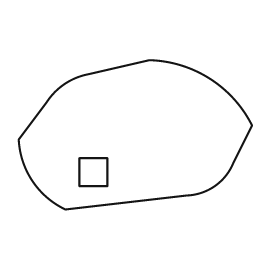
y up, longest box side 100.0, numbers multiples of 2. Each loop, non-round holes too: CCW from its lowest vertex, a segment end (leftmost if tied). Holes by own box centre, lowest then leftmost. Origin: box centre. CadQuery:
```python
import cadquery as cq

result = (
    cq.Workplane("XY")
    .moveTo(-30.0, -32.0)
    .lineTo(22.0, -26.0)
    .threePointArc((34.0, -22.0), (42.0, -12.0))
    .lineTo(50.0, 4.0)
    .threePointArc((32.0, 24.0), (6.0, 32.0))
    .lineTo(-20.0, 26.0)
    .threePointArc((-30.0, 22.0), (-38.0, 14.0))
    .lineTo(-50.0, -2.0)
    .threePointArc((-44.0, -20.0), (-30.0, -32.0))
    .close()
    .moveTo(-24.0, -22.0)
    .lineTo(-12.0, -22.0)
    .lineTo(-12.0, -10.0)
    .lineTo(-24.0, -10.0)
    .close()
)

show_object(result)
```